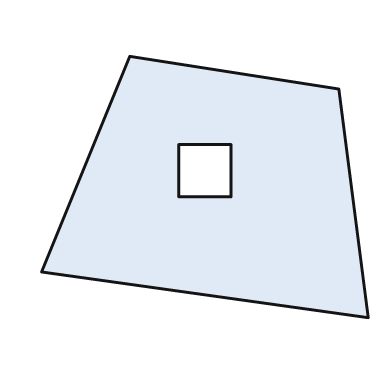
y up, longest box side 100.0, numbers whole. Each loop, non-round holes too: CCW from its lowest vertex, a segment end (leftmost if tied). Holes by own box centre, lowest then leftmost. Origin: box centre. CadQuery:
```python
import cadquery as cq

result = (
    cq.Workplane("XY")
    .moveTo(50.0, -40.0)
    .lineTo(41.0, 30.0)
    .lineTo(-23.0, 40.0)
    .lineTo(-50.0, -26.0)
    .close()
    .moveTo(-8.0, -3.0)
    .lineTo(8.0, -3.0)
    .lineTo(8.0, 13.0)
    .lineTo(-8.0, 13.0)
    .close()
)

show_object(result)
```